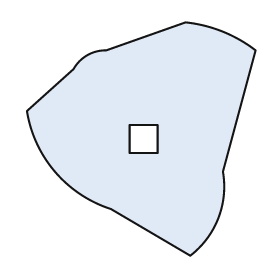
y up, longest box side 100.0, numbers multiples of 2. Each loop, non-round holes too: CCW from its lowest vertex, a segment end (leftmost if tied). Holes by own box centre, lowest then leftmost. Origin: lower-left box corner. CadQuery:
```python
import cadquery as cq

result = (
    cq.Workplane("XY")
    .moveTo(70.0, 0.0)
    .threePointArc((82.0, 16.0), (84.0, 36.0))
    .lineTo(98.0, 88.0)
    .threePointArc((84.0, 96.0), (68.0, 100.0))
    .lineTo(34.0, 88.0)
    .threePointArc((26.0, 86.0), (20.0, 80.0))
    .lineTo(0.0, 62.0)
    .threePointArc((12.0, 36.0), (36.0, 20.0))
    .close()
    .moveTo(44.0, 44.0)
    .lineTo(56.0, 44.0)
    .lineTo(56.0, 56.0)
    .lineTo(44.0, 56.0)
    .close()
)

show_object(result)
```